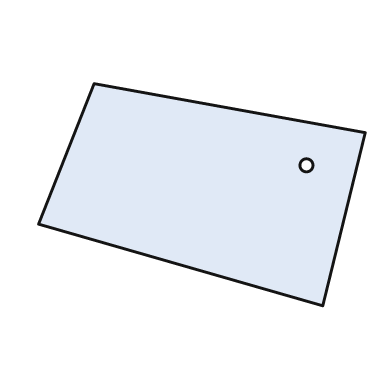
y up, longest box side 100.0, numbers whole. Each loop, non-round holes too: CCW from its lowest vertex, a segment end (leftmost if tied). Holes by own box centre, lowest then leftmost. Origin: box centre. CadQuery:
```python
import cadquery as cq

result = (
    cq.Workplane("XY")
    .moveTo(37.0, -34.0)
    .lineTo(50.0, 19.0)
    .lineTo(-33.0, 34.0)
    .lineTo(-50.0, -9.0)
    .close()
    .moveTo(32.0, 9.0)
    .circle(2.0)
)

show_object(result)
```